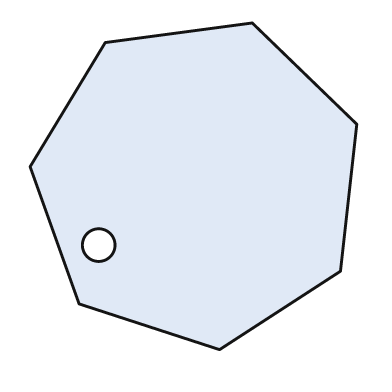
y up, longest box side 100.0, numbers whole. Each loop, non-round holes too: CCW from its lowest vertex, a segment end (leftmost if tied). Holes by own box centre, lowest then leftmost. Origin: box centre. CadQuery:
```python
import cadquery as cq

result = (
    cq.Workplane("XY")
    .moveTo(8.0, -50.0)
    .lineTo(45.0, -26.0)
    .lineTo(50.0, 19.0)
    .lineTo(18.0, 50.0)
    .lineTo(-27.0, 44.0)
    .lineTo(-50.0, 6.0)
    .lineTo(-35.0, -36.0)
    .close()
    .moveTo(-29.0, -18.0)
    .circle(5.0)
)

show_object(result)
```